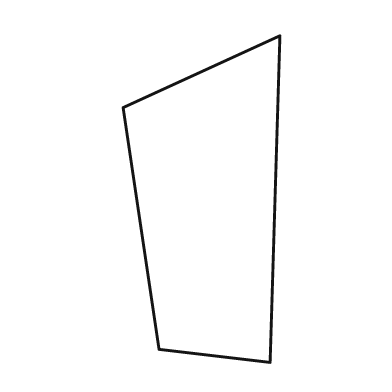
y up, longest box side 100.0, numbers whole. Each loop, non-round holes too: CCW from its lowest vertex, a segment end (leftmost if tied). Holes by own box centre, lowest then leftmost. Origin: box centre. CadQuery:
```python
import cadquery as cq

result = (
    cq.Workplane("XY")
    .moveTo(21.0, -50.0)
    .lineTo(24.0, 50.0)
    .lineTo(-24.0, 28.0)
    .lineTo(-13.0, -46.0)
    .close()
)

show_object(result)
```